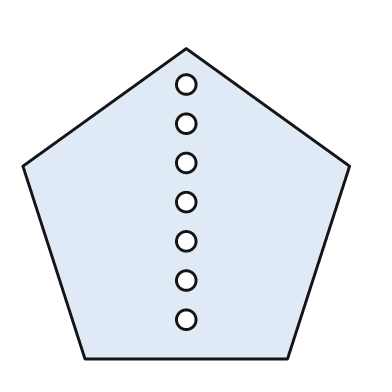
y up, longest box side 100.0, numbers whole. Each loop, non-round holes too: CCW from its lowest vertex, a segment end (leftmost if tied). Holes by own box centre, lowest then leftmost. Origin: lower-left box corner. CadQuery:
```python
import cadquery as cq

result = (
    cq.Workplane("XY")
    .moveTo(19.0, 0.0)
    .lineTo(81.0, 0.0)
    .lineTo(100.0, 59.0)
    .lineTo(50.0, 95.0)
    .lineTo(0.0, 59.0)
    .close()
    .moveTo(50.0, 12.0)
    .circle(3.0)
    .moveTo(50.0, 24.0)
    .circle(3.0)
    .moveTo(50.0, 36.0)
    .circle(3.0)
    .moveTo(50.0, 48.0)
    .circle(3.0)
    .moveTo(50.0, 60.0)
    .circle(3.0)
    .moveTo(50.0, 72.0)
    .circle(3.0)
    .moveTo(50.0, 84.0)
    .circle(3.0)
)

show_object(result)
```